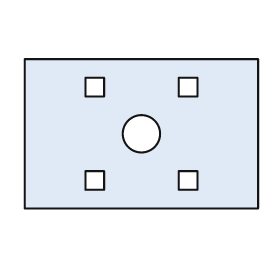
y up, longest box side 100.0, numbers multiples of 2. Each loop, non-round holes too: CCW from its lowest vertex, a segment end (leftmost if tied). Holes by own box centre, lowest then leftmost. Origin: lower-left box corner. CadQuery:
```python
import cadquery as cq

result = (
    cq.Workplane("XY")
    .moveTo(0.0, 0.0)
    .lineTo(100.0, 0.0)
    .lineTo(100.0, 64.0)
    .lineTo(0.0, 64.0)
    .close()
    .moveTo(26.0, 8.0)
    .lineTo(34.0, 8.0)
    .lineTo(34.0, 16.0)
    .lineTo(26.0, 16.0)
    .close()
    .moveTo(66.0, 8.0)
    .lineTo(74.0, 8.0)
    .lineTo(74.0, 16.0)
    .lineTo(66.0, 16.0)
    .close()
    .moveTo(50.0, 32.0)
    .circle(8.0)
    .moveTo(26.0, 48.0)
    .lineTo(34.0, 48.0)
    .lineTo(34.0, 56.0)
    .lineTo(26.0, 56.0)
    .close()
    .moveTo(66.0, 48.0)
    .lineTo(74.0, 48.0)
    .lineTo(74.0, 56.0)
    .lineTo(66.0, 56.0)
    .close()
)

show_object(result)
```